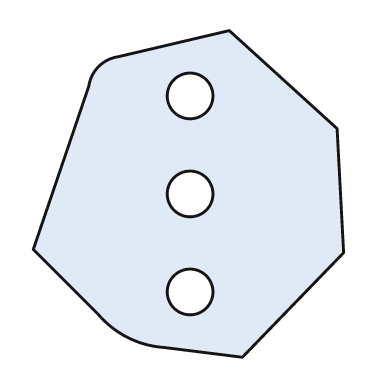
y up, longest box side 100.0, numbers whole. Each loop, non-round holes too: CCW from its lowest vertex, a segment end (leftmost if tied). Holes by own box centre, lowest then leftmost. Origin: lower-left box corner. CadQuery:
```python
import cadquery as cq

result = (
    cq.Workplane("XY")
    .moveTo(64.0, 0.0)
    .lineTo(95.0, 32.0)
    .lineTo(93.0, 70.0)
    .lineTo(60.0, 100.0)
    .lineTo(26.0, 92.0)
    .threePointArc((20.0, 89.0), (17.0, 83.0))
    .lineTo(0.0, 33.0)
    .lineTo(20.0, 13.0)
    .threePointArc((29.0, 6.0), (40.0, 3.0))
    .close()
    .moveTo(48.0, 20.0)
    .circle(7.0)
    .moveTo(48.0, 50.0)
    .circle(7.0)
    .moveTo(48.0, 80.0)
    .circle(7.0)
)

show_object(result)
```